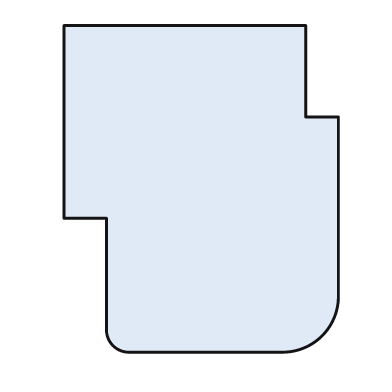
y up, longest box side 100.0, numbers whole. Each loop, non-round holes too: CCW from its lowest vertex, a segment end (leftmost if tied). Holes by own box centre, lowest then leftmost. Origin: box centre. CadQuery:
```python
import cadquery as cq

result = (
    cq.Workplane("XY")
    .moveTo(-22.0, -50.0)
    .lineTo(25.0, -50.0)
    .threePointArc((37.0, -45.0), (42.0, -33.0))
    .lineTo(42.0, 22.0)
    .lineTo(32.0, 22.0)
    .lineTo(32.0, 50.0)
    .lineTo(-42.0, 50.0)
    .lineTo(-42.0, -9.0)
    .lineTo(-29.0, -9.0)
    .lineTo(-29.0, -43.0)
    .threePointArc((-27.0, -48.0), (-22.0, -50.0))
    .close()
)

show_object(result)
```